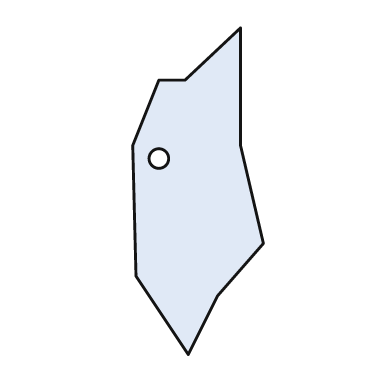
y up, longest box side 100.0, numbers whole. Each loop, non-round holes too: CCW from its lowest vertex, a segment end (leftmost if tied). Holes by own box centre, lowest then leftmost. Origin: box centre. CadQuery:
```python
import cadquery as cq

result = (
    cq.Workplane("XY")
    .moveTo(-3.0, -50.0)
    .lineTo(6.0, -32.0)
    .lineTo(20.0, -16.0)
    .lineTo(13.0, 14.0)
    .lineTo(13.0, 50.0)
    .lineTo(-4.0, 34.0)
    .lineTo(-12.0, 34.0)
    .lineTo(-20.0, 14.0)
    .lineTo(-19.0, -26.0)
    .close()
    .moveTo(-12.0, 10.0)
    .circle(3.0)
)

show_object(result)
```